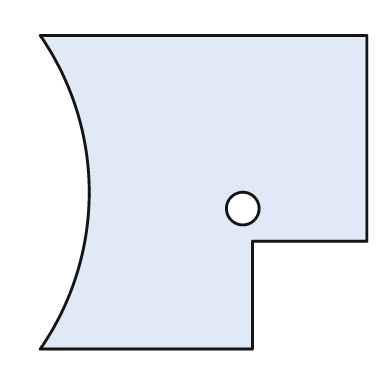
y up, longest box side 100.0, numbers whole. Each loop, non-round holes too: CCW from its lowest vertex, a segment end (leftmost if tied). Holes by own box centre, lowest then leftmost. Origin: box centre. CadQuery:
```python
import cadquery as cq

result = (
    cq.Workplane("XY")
    .moveTo(-50.0, -48.0)
    .lineTo(15.0, -48.0)
    .lineTo(15.0, -15.0)
    .lineTo(50.0, -15.0)
    .lineTo(50.0, 48.0)
    .lineTo(-50.0, 48.0)
    .threePointArc((-35.0, 0.0), (-50.0, -48.0))
    .close()
    .moveTo(12.0, -5.0)
    .circle(5.0)
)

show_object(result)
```